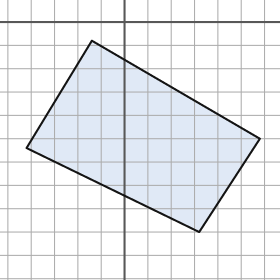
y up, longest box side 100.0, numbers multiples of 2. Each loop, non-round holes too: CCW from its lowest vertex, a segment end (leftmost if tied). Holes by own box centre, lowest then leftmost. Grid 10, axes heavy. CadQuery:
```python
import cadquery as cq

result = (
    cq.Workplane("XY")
    .moveTo(32.0, -90.0)
    .lineTo(58.0, -50.0)
    .lineTo(-14.0, -8.0)
    .lineTo(-42.0, -54.0)
    .close()
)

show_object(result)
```